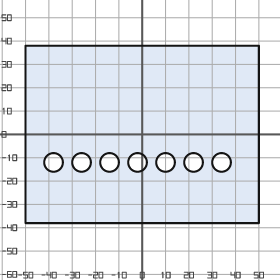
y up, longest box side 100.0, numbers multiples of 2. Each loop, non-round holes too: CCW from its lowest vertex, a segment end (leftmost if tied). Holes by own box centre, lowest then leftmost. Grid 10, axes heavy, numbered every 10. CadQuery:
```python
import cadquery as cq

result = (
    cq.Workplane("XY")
    .moveTo(-50.0, -38.0)
    .lineTo(50.0, -38.0)
    .lineTo(50.0, 38.0)
    .lineTo(-50.0, 38.0)
    .close()
    .moveTo(-38.0, -12.0)
    .circle(4.0)
    .moveTo(-26.0, -12.0)
    .circle(4.0)
    .moveTo(-14.0, -12.0)
    .circle(4.0)
    .moveTo(-2.0, -12.0)
    .circle(4.0)
    .moveTo(10.0, -12.0)
    .circle(4.0)
    .moveTo(22.0, -12.0)
    .circle(4.0)
    .moveTo(34.0, -12.0)
    .circle(4.0)
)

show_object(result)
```